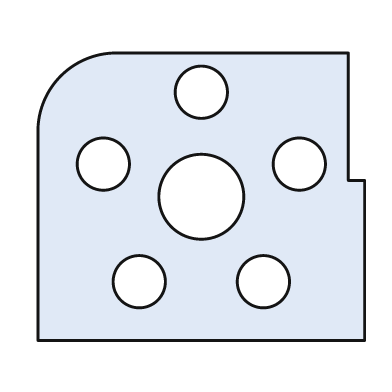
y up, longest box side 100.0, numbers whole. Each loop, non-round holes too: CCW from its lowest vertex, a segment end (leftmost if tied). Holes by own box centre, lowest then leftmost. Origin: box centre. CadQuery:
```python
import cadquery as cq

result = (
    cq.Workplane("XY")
    .moveTo(-50.0, -44.0)
    .lineTo(50.0, -44.0)
    .lineTo(50.0, 5.0)
    .lineTo(45.0, 5.0)
    .lineTo(45.0, 44.0)
    .lineTo(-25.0, 44.0)
    .threePointArc((-43.0, 37.0), (-50.0, 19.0))
    .close()
    .moveTo(-19.0, -26.0)
    .circle(8.0)
    .moveTo(19.0, -26.0)
    .circle(8.0)
    .moveTo(0.0, 0.0)
    .circle(13.0)
    .moveTo(-30.0, 10.0)
    .circle(8.0)
    .moveTo(30.0, 10.0)
    .circle(8.0)
    .moveTo(0.0, 32.0)
    .circle(8.0)
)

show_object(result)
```